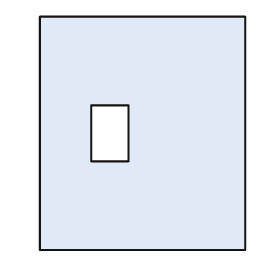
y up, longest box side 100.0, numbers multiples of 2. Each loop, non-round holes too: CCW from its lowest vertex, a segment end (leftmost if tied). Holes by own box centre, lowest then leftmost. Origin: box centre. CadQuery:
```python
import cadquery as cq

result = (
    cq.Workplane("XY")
    .moveTo(-44.0, -50.0)
    .lineTo(44.0, -50.0)
    .lineTo(44.0, 50.0)
    .lineTo(-44.0, 50.0)
    .close()
    .moveTo(-22.0, -12.0)
    .lineTo(-6.0, -12.0)
    .lineTo(-6.0, 12.0)
    .lineTo(-22.0, 12.0)
    .close()
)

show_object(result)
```